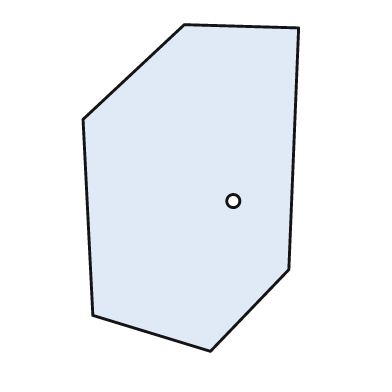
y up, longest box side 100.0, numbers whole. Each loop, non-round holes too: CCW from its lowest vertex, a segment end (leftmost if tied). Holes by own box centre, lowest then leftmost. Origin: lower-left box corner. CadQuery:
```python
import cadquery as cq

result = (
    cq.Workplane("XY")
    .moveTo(39.0, 0.0)
    .lineTo(63.0, 25.0)
    .lineTo(66.0, 99.0)
    .lineTo(31.0, 100.0)
    .lineTo(0.0, 71.0)
    .lineTo(3.0, 11.0)
    .close()
    .moveTo(46.0, 46.0)
    .circle(2.0)
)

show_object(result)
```